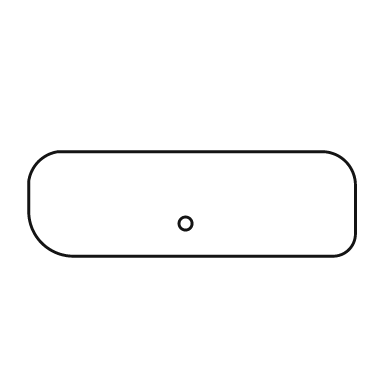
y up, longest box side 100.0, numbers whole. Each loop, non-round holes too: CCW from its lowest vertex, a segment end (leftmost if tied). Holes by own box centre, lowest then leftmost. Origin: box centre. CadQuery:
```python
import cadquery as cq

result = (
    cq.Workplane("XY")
    .moveTo(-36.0, -16.0)
    .lineTo(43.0, -16.0)
    .threePointArc((48.0, -14.0), (50.0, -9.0))
    .lineTo(50.0, 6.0)
    .threePointArc((47.0, 13.0), (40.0, 16.0))
    .lineTo(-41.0, 16.0)
    .threePointArc((-47.0, 13.0), (-50.0, 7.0))
    .lineTo(-50.0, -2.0)
    .threePointArc((-46.0, -12.0), (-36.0, -16.0))
    .close()
    .moveTo(-2.0, -6.0)
    .circle(2.0)
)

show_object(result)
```